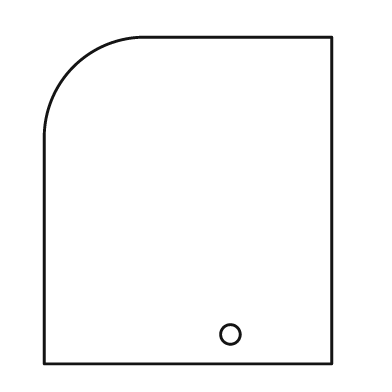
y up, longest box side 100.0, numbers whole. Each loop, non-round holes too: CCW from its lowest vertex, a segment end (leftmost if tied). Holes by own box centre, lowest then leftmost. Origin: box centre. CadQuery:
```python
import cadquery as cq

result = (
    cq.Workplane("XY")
    .moveTo(-44.0, -50.0)
    .lineTo(44.0, -50.0)
    .lineTo(44.0, 50.0)
    .lineTo(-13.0, 50.0)
    .threePointArc((-35.0, 41.0), (-44.0, 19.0))
    .close()
    .moveTo(13.0, -41.0)
    .circle(3.0)
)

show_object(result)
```